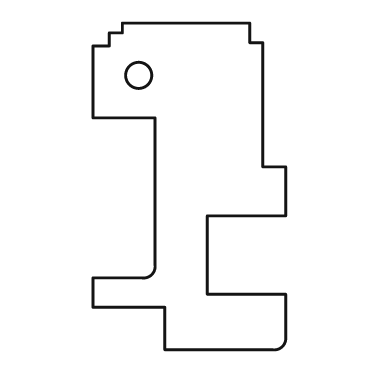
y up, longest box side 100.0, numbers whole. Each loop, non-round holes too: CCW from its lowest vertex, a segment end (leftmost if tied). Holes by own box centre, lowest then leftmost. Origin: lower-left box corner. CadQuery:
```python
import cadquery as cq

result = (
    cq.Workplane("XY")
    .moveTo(22.0, 0.0)
    .lineTo(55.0, 0.0)
    .threePointArc((58.0, 1.0), (59.0, 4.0))
    .lineTo(59.0, 17.0)
    .lineTo(35.0, 17.0)
    .lineTo(35.0, 41.0)
    .lineTo(59.0, 41.0)
    .lineTo(59.0, 56.0)
    .lineTo(52.0, 56.0)
    .lineTo(52.0, 94.0)
    .lineTo(48.0, 94.0)
    .lineTo(48.0, 100.0)
    .lineTo(9.0, 100.0)
    .lineTo(9.0, 97.0)
    .lineTo(5.0, 97.0)
    .lineTo(5.0, 93.0)
    .lineTo(0.0, 93.0)
    .lineTo(0.0, 71.0)
    .lineTo(19.0, 71.0)
    .lineTo(19.0, 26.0)
    .threePointArc((18.0, 23.0), (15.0, 22.0))
    .lineTo(0.0, 22.0)
    .lineTo(0.0, 13.0)
    .lineTo(22.0, 13.0)
    .close()
    .moveTo(14.0, 84.0)
    .circle(4.0)
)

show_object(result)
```